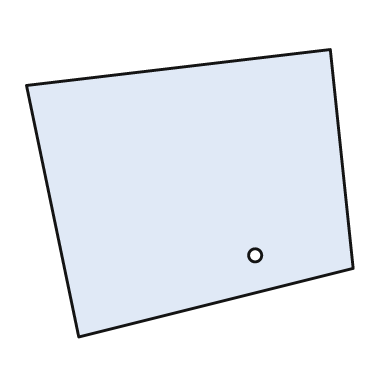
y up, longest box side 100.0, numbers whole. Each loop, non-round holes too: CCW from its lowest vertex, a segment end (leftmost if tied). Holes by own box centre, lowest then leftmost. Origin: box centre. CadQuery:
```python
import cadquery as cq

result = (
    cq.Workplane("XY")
    .moveTo(-34.0, -44.0)
    .lineTo(50.0, -23.0)
    .lineTo(43.0, 44.0)
    .lineTo(-50.0, 33.0)
    .close()
    .moveTo(20.0, -19.0)
    .circle(2.0)
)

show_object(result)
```